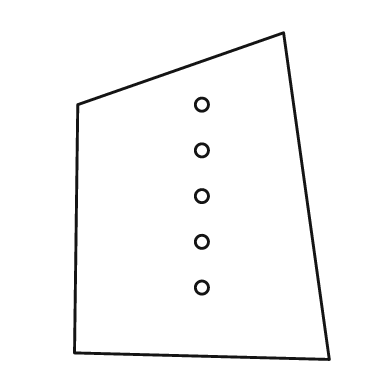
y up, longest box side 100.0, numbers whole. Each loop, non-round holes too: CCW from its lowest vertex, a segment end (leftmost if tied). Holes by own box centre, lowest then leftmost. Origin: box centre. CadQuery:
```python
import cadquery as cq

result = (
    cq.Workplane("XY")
    .moveTo(39.0, -50.0)
    .lineTo(25.0, 50.0)
    .lineTo(-38.0, 28.0)
    .lineTo(-39.0, -48.0)
    .close()
    .moveTo(0.0, -28.0)
    .circle(2.0)
    .moveTo(0.0, -14.0)
    .circle(2.0)
    .moveTo(0.0, 0.0)
    .circle(2.0)
    .moveTo(0.0, 14.0)
    .circle(2.0)
    .moveTo(0.0, 28.0)
    .circle(2.0)
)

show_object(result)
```